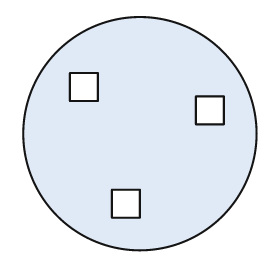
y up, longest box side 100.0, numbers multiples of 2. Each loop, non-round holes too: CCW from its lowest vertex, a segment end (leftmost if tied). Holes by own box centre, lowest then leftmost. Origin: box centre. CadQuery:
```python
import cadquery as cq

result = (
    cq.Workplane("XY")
    .moveTo(0.0, 0.0)
    .circle(50.0)
    .moveTo(-12.0, -36.0)
    .lineTo(0.0, -36.0)
    .lineTo(0.0, -24.0)
    .lineTo(-12.0, -24.0)
    .close()
    .moveTo(24.0, 4.0)
    .lineTo(36.0, 4.0)
    .lineTo(36.0, 16.0)
    .lineTo(24.0, 16.0)
    .close()
    .moveTo(-30.0, 14.0)
    .lineTo(-18.0, 14.0)
    .lineTo(-18.0, 26.0)
    .lineTo(-30.0, 26.0)
    .close()
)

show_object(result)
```